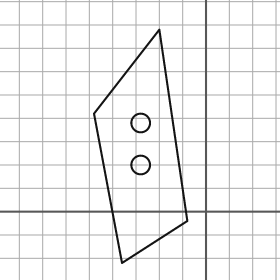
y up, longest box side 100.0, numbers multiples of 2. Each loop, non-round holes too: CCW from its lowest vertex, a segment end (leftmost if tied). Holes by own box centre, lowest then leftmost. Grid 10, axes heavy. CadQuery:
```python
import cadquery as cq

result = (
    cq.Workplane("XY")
    .moveTo(-36.0, -22.0)
    .lineTo(-8.0, -4.0)
    .lineTo(-20.0, 78.0)
    .lineTo(-48.0, 42.0)
    .close()
    .moveTo(-28.0, 20.0)
    .circle(4.0)
    .moveTo(-28.0, 38.0)
    .circle(4.0)
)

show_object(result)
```